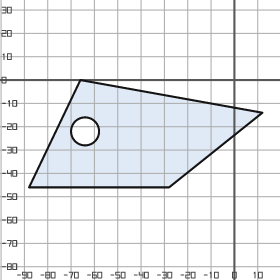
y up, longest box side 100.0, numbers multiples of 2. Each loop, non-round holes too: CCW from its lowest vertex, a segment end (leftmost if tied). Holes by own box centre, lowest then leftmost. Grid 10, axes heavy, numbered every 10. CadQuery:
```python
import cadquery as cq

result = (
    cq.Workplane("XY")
    .moveTo(-88.0, -46.0)
    .lineTo(-28.0, -46.0)
    .lineTo(12.0, -14.0)
    .lineTo(-66.0, 0.0)
    .close()
    .moveTo(-64.0, -22.0)
    .circle(6.0)
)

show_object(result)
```